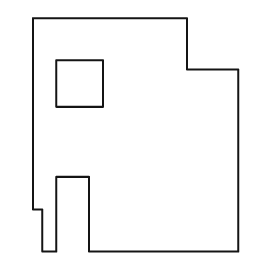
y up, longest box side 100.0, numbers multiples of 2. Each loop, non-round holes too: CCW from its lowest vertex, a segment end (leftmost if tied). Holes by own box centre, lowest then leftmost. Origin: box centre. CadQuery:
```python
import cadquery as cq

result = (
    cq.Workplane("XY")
    .moveTo(-40.0, -50.0)
    .lineTo(-34.0, -50.0)
    .lineTo(-34.0, -18.0)
    .lineTo(-20.0, -18.0)
    .lineTo(-20.0, -50.0)
    .lineTo(44.0, -50.0)
    .lineTo(44.0, 28.0)
    .lineTo(22.0, 28.0)
    .lineTo(22.0, 50.0)
    .lineTo(-44.0, 50.0)
    .lineTo(-44.0, -32.0)
    .lineTo(-40.0, -32.0)
    .close()
    .moveTo(-34.0, 12.0)
    .lineTo(-14.0, 12.0)
    .lineTo(-14.0, 32.0)
    .lineTo(-34.0, 32.0)
    .close()
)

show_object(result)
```